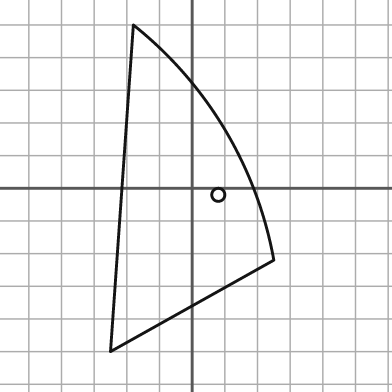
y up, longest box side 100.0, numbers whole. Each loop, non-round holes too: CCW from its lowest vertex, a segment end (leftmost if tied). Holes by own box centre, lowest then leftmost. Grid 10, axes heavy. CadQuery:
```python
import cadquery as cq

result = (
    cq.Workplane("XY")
    .moveTo(-25.0, -50.0)
    .lineTo(25.0, -22.0)
    .threePointArc((10.0, 18.0), (-18.0, 50.0))
    .close()
    .moveTo(8.0, -2.0)
    .circle(2.0)
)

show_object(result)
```